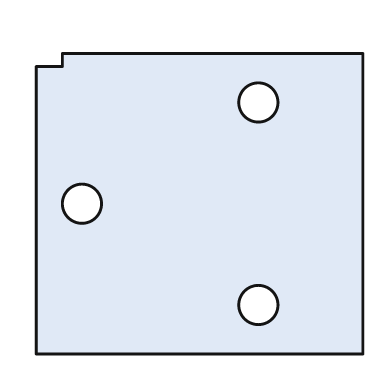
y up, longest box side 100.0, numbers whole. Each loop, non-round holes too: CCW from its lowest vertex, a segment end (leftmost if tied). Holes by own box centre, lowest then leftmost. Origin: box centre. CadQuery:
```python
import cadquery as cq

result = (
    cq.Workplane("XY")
    .moveTo(-50.0, -46.0)
    .lineTo(50.0, -46.0)
    .lineTo(50.0, 46.0)
    .lineTo(-42.0, 46.0)
    .lineTo(-42.0, 42.0)
    .lineTo(-50.0, 42.0)
    .close()
    .moveTo(18.0, -31.0)
    .circle(6.0)
    .moveTo(-36.0, 0.0)
    .circle(6.0)
    .moveTo(18.0, 31.0)
    .circle(6.0)
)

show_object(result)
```